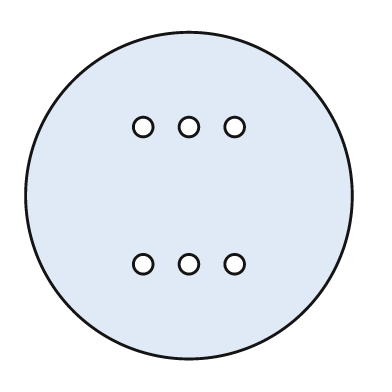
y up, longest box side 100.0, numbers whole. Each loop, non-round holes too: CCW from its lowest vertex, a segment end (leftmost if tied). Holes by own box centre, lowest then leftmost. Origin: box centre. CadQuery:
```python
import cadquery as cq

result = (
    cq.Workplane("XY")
    .moveTo(0.0, 0.0)
    .circle(50.0)
    .moveTo(-14.0, -21.0)
    .circle(3.0)
    .moveTo(0.0, -21.0)
    .circle(3.0)
    .moveTo(14.0, -21.0)
    .circle(3.0)
    .moveTo(-14.0, 21.0)
    .circle(3.0)
    .moveTo(0.0, 21.0)
    .circle(3.0)
    .moveTo(14.0, 21.0)
    .circle(3.0)
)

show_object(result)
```